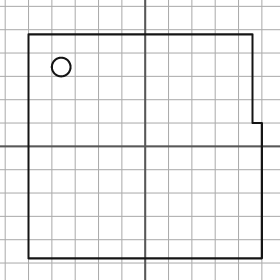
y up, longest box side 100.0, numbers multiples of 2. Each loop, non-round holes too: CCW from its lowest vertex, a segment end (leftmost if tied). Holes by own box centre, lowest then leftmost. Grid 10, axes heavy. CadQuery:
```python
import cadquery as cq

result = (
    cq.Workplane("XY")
    .moveTo(-50.0, -48.0)
    .lineTo(50.0, -48.0)
    .lineTo(50.0, 10.0)
    .lineTo(46.0, 10.0)
    .lineTo(46.0, 48.0)
    .lineTo(-50.0, 48.0)
    .close()
    .moveTo(-36.0, 34.0)
    .circle(4.0)
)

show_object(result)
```